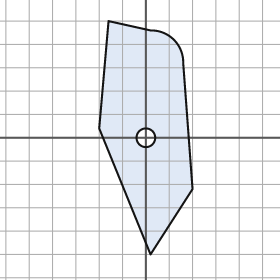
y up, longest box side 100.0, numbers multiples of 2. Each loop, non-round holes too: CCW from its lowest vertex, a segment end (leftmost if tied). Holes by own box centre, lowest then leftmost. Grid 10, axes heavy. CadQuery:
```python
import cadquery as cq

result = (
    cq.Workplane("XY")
    .moveTo(2.0, -50.0)
    .lineTo(20.0, -22.0)
    .lineTo(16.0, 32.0)
    .threePointArc((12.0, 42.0), (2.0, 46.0))
    .lineTo(-16.0, 50.0)
    .lineTo(-20.0, 4.0)
    .close()
    .moveTo(0.0, 0.0)
    .circle(4.0)
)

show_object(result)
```